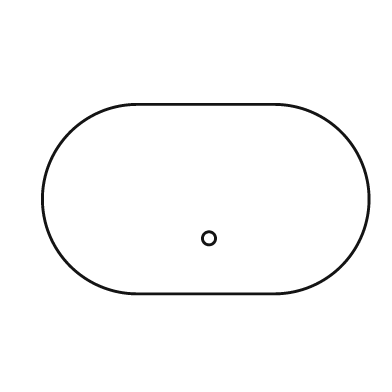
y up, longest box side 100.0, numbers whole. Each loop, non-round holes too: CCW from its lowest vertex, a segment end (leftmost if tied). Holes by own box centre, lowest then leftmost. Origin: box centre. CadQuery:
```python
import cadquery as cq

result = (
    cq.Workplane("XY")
    .moveTo(-21.0, -29.0)
    .lineTo(21.0, -29.0)
    .threePointArc((50.0, 0.0), (21.0, 29.0))
    .lineTo(-21.0, 29.0)
    .threePointArc((-50.0, 0.0), (-21.0, -29.0))
    .close()
    .moveTo(1.0, -12.0)
    .circle(2.0)
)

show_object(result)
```